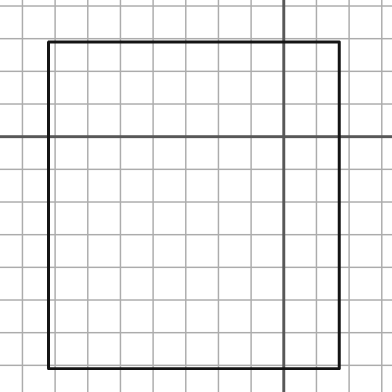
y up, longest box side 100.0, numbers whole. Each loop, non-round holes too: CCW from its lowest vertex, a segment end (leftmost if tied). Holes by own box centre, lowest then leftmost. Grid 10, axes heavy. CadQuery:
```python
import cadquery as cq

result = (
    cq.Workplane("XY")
    .moveTo(-72.0, -71.0)
    .lineTo(17.0, -71.0)
    .lineTo(17.0, 29.0)
    .lineTo(-72.0, 29.0)
    .close()
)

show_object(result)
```